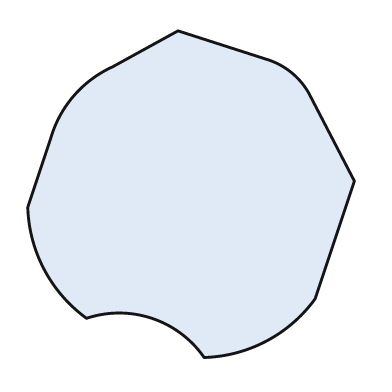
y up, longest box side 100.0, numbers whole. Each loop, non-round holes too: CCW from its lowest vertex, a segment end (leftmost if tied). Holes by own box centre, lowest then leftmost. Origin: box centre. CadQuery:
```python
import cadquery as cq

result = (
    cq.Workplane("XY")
    .moveTo(4.0, -50.0)
    .threePointArc((23.0, -45.0), (38.0, -32.0))
    .lineTo(50.0, 4.0)
    .lineTo(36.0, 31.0)
    .threePointArc((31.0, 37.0), (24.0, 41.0))
    .lineTo(-4.0, 50.0)
    .lineTo(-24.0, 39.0)
    .threePointArc((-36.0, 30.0), (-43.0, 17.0))
    .lineTo(-50.0, -4.0)
    .threePointArc((-45.0, -23.0), (-32.0, -38.0))
    .threePointArc((-12.0, -38.0), (4.0, -50.0))
    .close()
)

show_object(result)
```